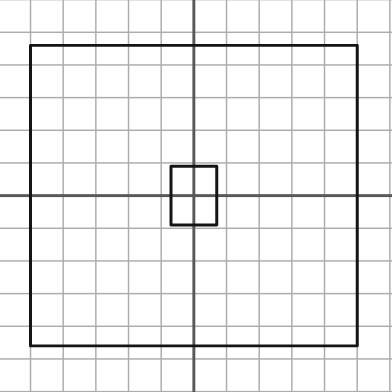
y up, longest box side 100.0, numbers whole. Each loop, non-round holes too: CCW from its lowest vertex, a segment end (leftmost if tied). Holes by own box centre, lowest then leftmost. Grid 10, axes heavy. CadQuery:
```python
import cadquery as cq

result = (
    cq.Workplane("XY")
    .moveTo(-50.0, -46.0)
    .lineTo(50.0, -46.0)
    .lineTo(50.0, 46.0)
    .lineTo(-50.0, 46.0)
    .close()
    .moveTo(-7.0, -9.0)
    .lineTo(7.0, -9.0)
    .lineTo(7.0, 9.0)
    .lineTo(-7.0, 9.0)
    .close()
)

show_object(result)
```